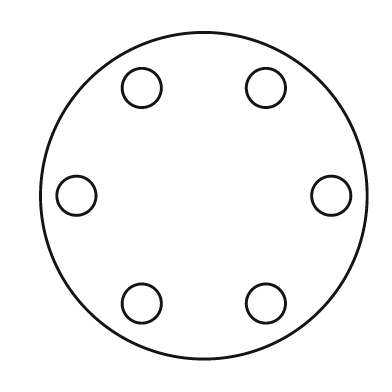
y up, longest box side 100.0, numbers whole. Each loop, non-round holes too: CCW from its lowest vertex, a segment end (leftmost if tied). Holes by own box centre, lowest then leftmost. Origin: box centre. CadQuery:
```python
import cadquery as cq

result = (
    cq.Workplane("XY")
    .moveTo(0.0, 0.0)
    .circle(50.0)
    .moveTo(-19.0, -33.0)
    .circle(6.0)
    .moveTo(19.0, -33.0)
    .circle(6.0)
    .moveTo(-39.0, 0.0)
    .circle(6.0)
    .moveTo(39.0, 0.0)
    .circle(6.0)
    .moveTo(-19.0, 33.0)
    .circle(6.0)
    .moveTo(19.0, 33.0)
    .circle(6.0)
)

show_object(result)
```